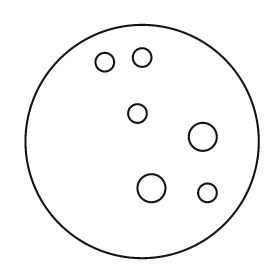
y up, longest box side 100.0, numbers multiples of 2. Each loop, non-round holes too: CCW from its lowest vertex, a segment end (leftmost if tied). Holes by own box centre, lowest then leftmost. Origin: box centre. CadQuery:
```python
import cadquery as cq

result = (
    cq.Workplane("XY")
    .moveTo(0.0, 0.0)
    .circle(50.0)
    .moveTo(28.0, -22.0)
    .circle(4.0)
    .moveTo(4.0, -20.0)
    .circle(6.0)
    .moveTo(26.0, 2.0)
    .circle(6.0)
    .moveTo(-2.0, 12.0)
    .circle(4.0)
    .moveTo(-16.0, 34.0)
    .circle(4.0)
    .moveTo(0.0, 36.0)
    .circle(4.0)
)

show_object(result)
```